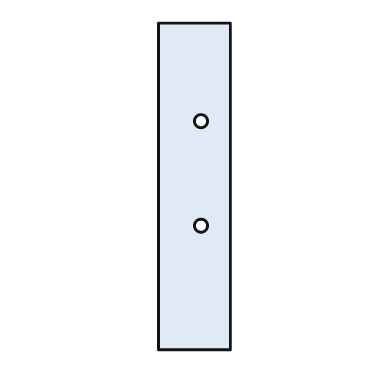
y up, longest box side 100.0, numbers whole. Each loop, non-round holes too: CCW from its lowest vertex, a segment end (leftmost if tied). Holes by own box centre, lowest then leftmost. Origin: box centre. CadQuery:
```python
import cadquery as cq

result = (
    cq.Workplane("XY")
    .moveTo(-11.0, -50.0)
    .lineTo(11.0, -50.0)
    .lineTo(11.0, 50.0)
    .lineTo(-11.0, 50.0)
    .close()
    .moveTo(2.0, -12.0)
    .circle(2.0)
    .moveTo(2.0, 20.0)
    .circle(2.0)
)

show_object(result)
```